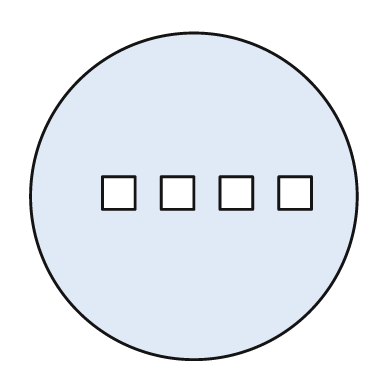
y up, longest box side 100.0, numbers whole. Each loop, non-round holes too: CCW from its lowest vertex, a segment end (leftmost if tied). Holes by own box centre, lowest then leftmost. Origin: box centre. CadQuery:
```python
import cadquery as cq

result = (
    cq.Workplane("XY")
    .moveTo(0.0, 0.0)
    .circle(50.0)
    .moveTo(-28.0, -4.0)
    .lineTo(-18.0, -4.0)
    .lineTo(-18.0, 6.0)
    .lineTo(-28.0, 6.0)
    .close()
    .moveTo(-10.0, -4.0)
    .lineTo(0.0, -4.0)
    .lineTo(0.0, 6.0)
    .lineTo(-10.0, 6.0)
    .close()
    .moveTo(8.0, -4.0)
    .lineTo(18.0, -4.0)
    .lineTo(18.0, 6.0)
    .lineTo(8.0, 6.0)
    .close()
    .moveTo(26.0, -4.0)
    .lineTo(36.0, -4.0)
    .lineTo(36.0, 6.0)
    .lineTo(26.0, 6.0)
    .close()
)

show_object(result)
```